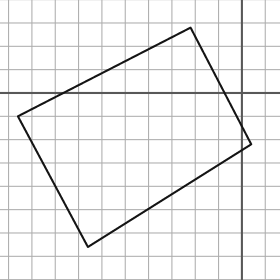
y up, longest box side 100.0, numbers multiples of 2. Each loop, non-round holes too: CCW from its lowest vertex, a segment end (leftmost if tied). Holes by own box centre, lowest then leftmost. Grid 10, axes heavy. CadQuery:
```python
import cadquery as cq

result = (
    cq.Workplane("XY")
    .moveTo(-66.0, -66.0)
    .lineTo(4.0, -22.0)
    .lineTo(-22.0, 28.0)
    .lineTo(-96.0, -10.0)
    .close()
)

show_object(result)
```